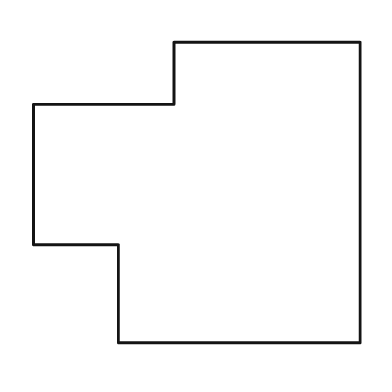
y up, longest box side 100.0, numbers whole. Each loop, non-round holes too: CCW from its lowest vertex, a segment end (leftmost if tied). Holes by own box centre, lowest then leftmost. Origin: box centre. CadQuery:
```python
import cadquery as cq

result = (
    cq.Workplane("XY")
    .moveTo(-24.0, -46.0)
    .lineTo(50.0, -46.0)
    .lineTo(50.0, 46.0)
    .lineTo(-7.0, 46.0)
    .lineTo(-7.0, 27.0)
    .lineTo(-50.0, 27.0)
    .lineTo(-50.0, -16.0)
    .lineTo(-24.0, -16.0)
    .close()
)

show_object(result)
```